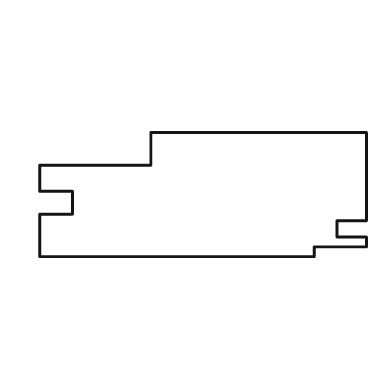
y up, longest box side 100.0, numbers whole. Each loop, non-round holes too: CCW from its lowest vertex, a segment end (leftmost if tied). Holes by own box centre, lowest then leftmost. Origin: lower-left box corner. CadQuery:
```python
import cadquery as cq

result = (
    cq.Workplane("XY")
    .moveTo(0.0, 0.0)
    .lineTo(84.0, 0.0)
    .lineTo(84.0, 3.0)
    .lineTo(100.0, 3.0)
    .lineTo(100.0, 6.0)
    .lineTo(91.0, 6.0)
    .lineTo(91.0, 11.0)
    .lineTo(100.0, 11.0)
    .lineTo(100.0, 38.0)
    .lineTo(34.0, 38.0)
    .lineTo(34.0, 28.0)
    .lineTo(0.0, 28.0)
    .lineTo(0.0, 20.0)
    .lineTo(10.0, 20.0)
    .lineTo(10.0, 13.0)
    .lineTo(0.0, 13.0)
    .close()
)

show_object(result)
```